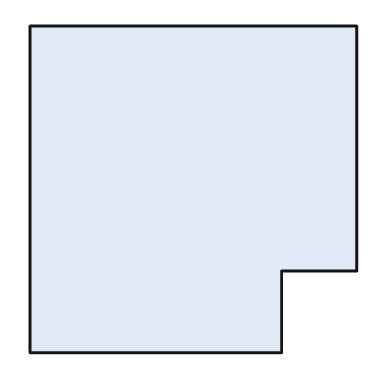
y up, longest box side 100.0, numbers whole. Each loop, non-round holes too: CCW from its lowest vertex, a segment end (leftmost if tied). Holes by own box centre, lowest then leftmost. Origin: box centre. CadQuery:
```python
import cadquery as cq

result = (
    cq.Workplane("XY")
    .moveTo(-50.0, -50.0)
    .lineTo(27.0, -50.0)
    .lineTo(27.0, -25.0)
    .lineTo(50.0, -25.0)
    .lineTo(50.0, 50.0)
    .lineTo(-50.0, 50.0)
    .close()
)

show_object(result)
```